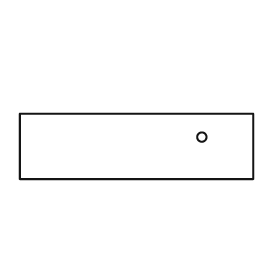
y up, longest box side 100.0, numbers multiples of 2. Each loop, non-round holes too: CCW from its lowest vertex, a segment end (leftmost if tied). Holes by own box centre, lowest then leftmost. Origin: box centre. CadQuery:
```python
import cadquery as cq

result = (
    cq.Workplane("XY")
    .moveTo(-50.0, -14.0)
    .lineTo(50.0, -14.0)
    .lineTo(50.0, 14.0)
    .lineTo(-50.0, 14.0)
    .close()
    .moveTo(28.0, 4.0)
    .circle(2.0)
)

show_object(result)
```